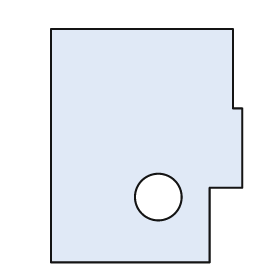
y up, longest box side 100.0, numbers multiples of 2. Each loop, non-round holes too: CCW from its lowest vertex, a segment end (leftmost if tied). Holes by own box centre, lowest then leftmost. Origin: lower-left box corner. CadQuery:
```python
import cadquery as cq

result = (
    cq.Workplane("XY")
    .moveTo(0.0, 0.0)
    .lineTo(68.0, 0.0)
    .lineTo(68.0, 32.0)
    .lineTo(82.0, 32.0)
    .lineTo(82.0, 66.0)
    .lineTo(78.0, 66.0)
    .lineTo(78.0, 100.0)
    .lineTo(0.0, 100.0)
    .close()
    .moveTo(46.0, 28.0)
    .circle(10.0)
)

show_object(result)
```